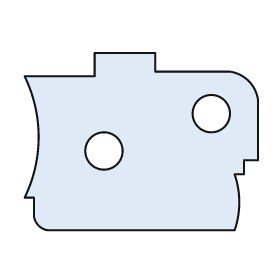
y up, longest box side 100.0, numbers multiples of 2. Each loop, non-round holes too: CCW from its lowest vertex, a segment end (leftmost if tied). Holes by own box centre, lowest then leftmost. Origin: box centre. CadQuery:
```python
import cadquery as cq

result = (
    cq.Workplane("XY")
    .moveTo(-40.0, -38.0)
    .lineTo(40.0, -38.0)
    .threePointArc((42.0, -26.0), (40.0, -14.0))
    .lineTo(44.0, -14.0)
    .lineTo(44.0, -8.0)
    .lineTo(50.0, -8.0)
    .lineTo(50.0, 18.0)
    .threePointArc((46.0, 26.0), (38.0, 30.0))
    .lineTo(6.0, 30.0)
    .lineTo(6.0, 38.0)
    .lineTo(-20.0, 38.0)
    .lineTo(-20.0, 28.0)
    .lineTo(-50.0, 28.0)
    .threePointArc((-44.0, 2.0), (-50.0, -24.0))
    .lineTo(-46.0, -24.0)
    .lineTo(-46.0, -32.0)
    .threePointArc((-44.0, -36.0), (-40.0, -38.0))
    .close()
    .moveTo(-16.0, -4.0)
    .circle(8.0)
    .moveTo(30.0, 12.0)
    .circle(8.0)
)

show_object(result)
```